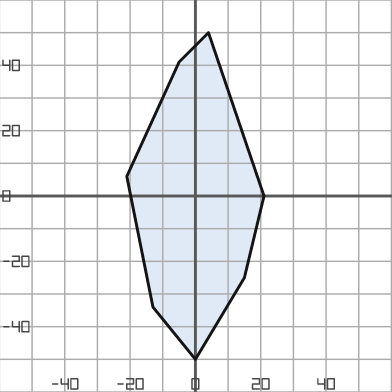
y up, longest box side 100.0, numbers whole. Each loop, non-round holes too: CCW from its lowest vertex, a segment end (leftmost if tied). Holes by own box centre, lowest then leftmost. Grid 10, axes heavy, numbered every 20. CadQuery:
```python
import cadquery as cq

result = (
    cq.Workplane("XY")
    .moveTo(0.0, -50.0)
    .lineTo(15.0, -25.0)
    .lineTo(21.0, 0.0)
    .lineTo(4.0, 50.0)
    .lineTo(-5.0, 41.0)
    .lineTo(-21.0, 6.0)
    .lineTo(-13.0, -34.0)
    .close()
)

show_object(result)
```